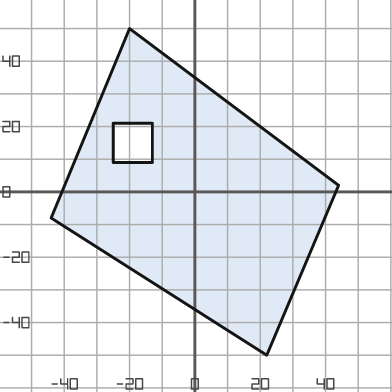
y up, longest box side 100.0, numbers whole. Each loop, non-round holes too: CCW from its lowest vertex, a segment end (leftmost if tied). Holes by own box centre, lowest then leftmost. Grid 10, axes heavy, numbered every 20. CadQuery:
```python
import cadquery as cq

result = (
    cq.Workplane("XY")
    .moveTo(22.0, -50.0)
    .lineTo(44.0, 2.0)
    .lineTo(-20.0, 50.0)
    .lineTo(-44.0, -8.0)
    .close()
    .moveTo(-25.0, 9.0)
    .lineTo(-13.0, 9.0)
    .lineTo(-13.0, 21.0)
    .lineTo(-25.0, 21.0)
    .close()
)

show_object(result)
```